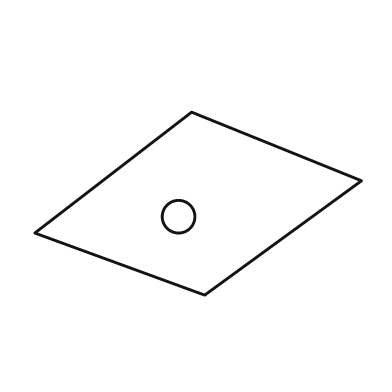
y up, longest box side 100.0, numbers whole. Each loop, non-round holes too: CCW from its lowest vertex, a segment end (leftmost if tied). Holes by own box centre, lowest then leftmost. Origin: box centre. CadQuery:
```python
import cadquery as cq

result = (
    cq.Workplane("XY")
    .moveTo(2.0, -28.0)
    .lineTo(50.0, 7.0)
    .lineTo(-2.0, 28.0)
    .lineTo(-50.0, -9.0)
    .close()
    .moveTo(-6.0, -4.0)
    .circle(5.0)
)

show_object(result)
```